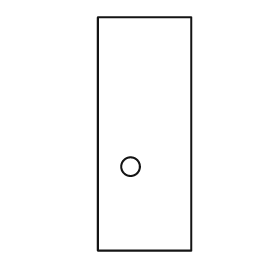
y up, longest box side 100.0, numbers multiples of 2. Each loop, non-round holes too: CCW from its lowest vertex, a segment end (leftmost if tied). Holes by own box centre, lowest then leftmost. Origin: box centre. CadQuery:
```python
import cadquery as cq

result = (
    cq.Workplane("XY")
    .moveTo(-20.0, -50.0)
    .lineTo(20.0, -50.0)
    .lineTo(20.0, 50.0)
    .lineTo(-20.0, 50.0)
    .close()
    .moveTo(-6.0, -14.0)
    .circle(4.0)
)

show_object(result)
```